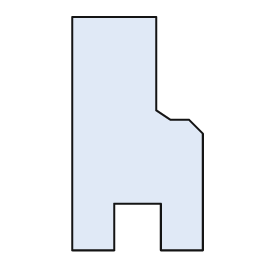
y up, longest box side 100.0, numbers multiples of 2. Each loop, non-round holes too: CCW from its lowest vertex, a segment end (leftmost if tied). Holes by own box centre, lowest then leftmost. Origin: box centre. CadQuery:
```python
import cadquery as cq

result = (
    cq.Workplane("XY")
    .moveTo(-28.0, -50.0)
    .lineTo(-10.0, -50.0)
    .lineTo(-10.0, -30.0)
    .lineTo(10.0, -30.0)
    .lineTo(10.0, -50.0)
    .lineTo(28.0, -50.0)
    .lineTo(28.0, 0.0)
    .lineTo(22.0, 6.0)
    .lineTo(14.0, 6.0)
    .lineTo(8.0, 10.0)
    .lineTo(8.0, 50.0)
    .lineTo(-28.0, 50.0)
    .close()
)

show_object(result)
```